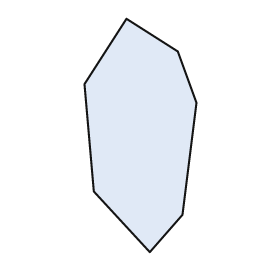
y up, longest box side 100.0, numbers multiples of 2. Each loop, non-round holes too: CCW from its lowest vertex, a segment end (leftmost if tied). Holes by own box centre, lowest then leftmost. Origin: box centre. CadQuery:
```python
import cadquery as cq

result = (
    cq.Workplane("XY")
    .moveTo(4.0, -50.0)
    .lineTo(18.0, -34.0)
    .lineTo(24.0, 14.0)
    .lineTo(16.0, 36.0)
    .lineTo(-6.0, 50.0)
    .lineTo(-24.0, 22.0)
    .lineTo(-20.0, -24.0)
    .close()
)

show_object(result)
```